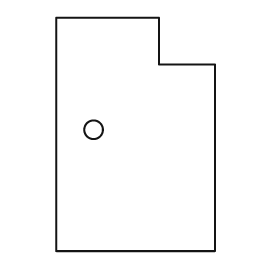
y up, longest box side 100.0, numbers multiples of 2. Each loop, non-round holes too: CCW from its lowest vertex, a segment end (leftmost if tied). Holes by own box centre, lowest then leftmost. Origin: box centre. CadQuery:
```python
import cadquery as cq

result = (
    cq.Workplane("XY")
    .moveTo(-34.0, -50.0)
    .lineTo(34.0, -50.0)
    .lineTo(34.0, 30.0)
    .lineTo(10.0, 30.0)
    .lineTo(10.0, 50.0)
    .lineTo(-34.0, 50.0)
    .close()
    .moveTo(-18.0, 2.0)
    .circle(4.0)
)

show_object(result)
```